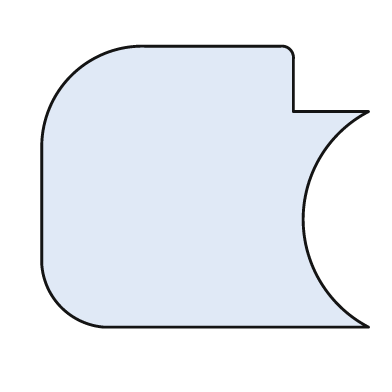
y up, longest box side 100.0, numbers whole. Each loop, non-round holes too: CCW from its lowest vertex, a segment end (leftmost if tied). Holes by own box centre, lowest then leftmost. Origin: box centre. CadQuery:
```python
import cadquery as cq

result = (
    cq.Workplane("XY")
    .moveTo(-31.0, -43.0)
    .lineTo(50.0, -43.0)
    .threePointArc((30.0, -10.0), (50.0, 23.0))
    .lineTo(27.0, 23.0)
    .lineTo(27.0, 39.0)
    .threePointArc((26.0, 42.0), (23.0, 43.0))
    .lineTo(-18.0, 43.0)
    .threePointArc((-41.0, 34.0), (-50.0, 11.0))
    .lineTo(-50.0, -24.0)
    .threePointArc((-44.0, -37.0), (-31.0, -43.0))
    .close()
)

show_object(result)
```